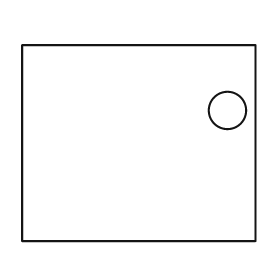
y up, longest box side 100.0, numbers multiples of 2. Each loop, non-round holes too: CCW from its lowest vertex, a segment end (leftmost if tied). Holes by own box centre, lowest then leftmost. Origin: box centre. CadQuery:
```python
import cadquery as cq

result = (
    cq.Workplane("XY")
    .moveTo(-50.0, -42.0)
    .lineTo(50.0, -42.0)
    .lineTo(50.0, 42.0)
    .lineTo(-50.0, 42.0)
    .close()
    .moveTo(38.0, 14.0)
    .circle(8.0)
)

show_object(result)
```